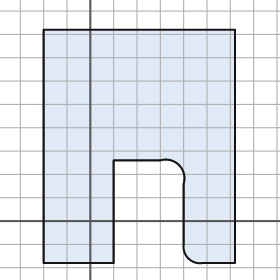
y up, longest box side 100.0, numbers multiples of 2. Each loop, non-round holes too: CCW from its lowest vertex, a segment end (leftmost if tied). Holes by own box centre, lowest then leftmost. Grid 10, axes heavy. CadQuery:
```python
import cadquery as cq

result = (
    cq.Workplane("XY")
    .moveTo(-20.0, -18.0)
    .lineTo(10.0, -18.0)
    .lineTo(10.0, 26.0)
    .lineTo(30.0, 26.0)
    .threePointArc((38.0, 24.0), (40.0, 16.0))
    .lineTo(40.0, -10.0)
    .threePointArc((42.0, -16.0), (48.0, -18.0))
    .lineTo(62.0, -18.0)
    .lineTo(62.0, 82.0)
    .lineTo(-20.0, 82.0)
    .close()
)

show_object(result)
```